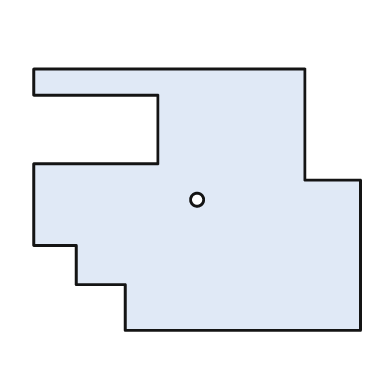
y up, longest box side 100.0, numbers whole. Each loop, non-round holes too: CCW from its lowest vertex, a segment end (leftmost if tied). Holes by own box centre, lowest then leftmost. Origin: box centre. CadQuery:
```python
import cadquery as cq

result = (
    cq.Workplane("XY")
    .moveTo(-22.0, -40.0)
    .lineTo(50.0, -40.0)
    .lineTo(50.0, 6.0)
    .lineTo(33.0, 6.0)
    .lineTo(33.0, 40.0)
    .lineTo(-50.0, 40.0)
    .lineTo(-50.0, 32.0)
    .lineTo(-12.0, 32.0)
    .lineTo(-12.0, 11.0)
    .lineTo(-50.0, 11.0)
    .lineTo(-50.0, -14.0)
    .lineTo(-37.0, -14.0)
    .lineTo(-37.0, -26.0)
    .lineTo(-22.0, -26.0)
    .close()
    .moveTo(0.0, 0.0)
    .circle(2.0)
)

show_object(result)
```